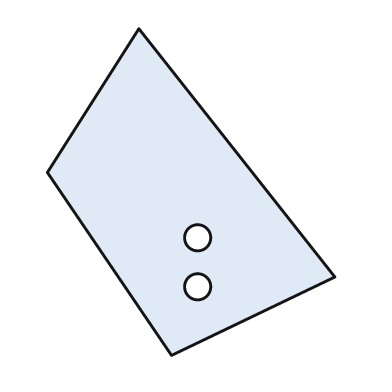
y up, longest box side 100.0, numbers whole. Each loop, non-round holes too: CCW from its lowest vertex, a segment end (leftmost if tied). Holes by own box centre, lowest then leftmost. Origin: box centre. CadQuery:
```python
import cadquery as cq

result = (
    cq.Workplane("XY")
    .moveTo(-6.0, -50.0)
    .lineTo(44.0, -26.0)
    .lineTo(-16.0, 50.0)
    .lineTo(-44.0, 6.0)
    .close()
    .moveTo(2.0, -29.0)
    .circle(4.0)
    .moveTo(2.0, -14.0)
    .circle(4.0)
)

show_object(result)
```